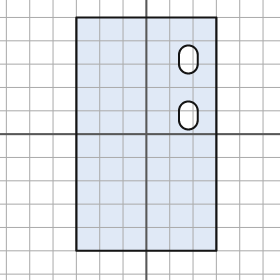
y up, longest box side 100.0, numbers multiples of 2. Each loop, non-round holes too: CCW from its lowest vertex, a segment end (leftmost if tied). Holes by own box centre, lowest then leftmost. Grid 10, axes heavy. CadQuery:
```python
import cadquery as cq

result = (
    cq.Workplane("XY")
    .moveTo(-30.0, -50.0)
    .lineTo(30.0, -50.0)
    .lineTo(30.0, 50.0)
    .lineTo(-30.0, 50.0)
    .close()
    .moveTo(14.0, 6.0)
    .threePointArc((18.0, 2.0), (22.0, 6.0))
    .lineTo(22.0, 10.0)
    .threePointArc((18.0, 14.0), (14.0, 10.0))
    .close()
    .moveTo(14.0, 30.0)
    .threePointArc((18.0, 26.0), (22.0, 30.0))
    .lineTo(22.0, 34.0)
    .threePointArc((18.0, 38.0), (14.0, 34.0))
    .close()
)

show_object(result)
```